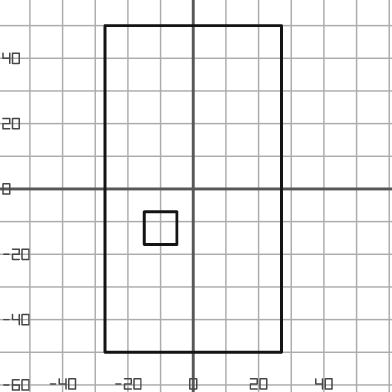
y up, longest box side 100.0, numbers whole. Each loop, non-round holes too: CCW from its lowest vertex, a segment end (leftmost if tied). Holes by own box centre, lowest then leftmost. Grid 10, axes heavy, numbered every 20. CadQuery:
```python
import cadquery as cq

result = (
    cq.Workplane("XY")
    .moveTo(-27.0, -50.0)
    .lineTo(27.0, -50.0)
    .lineTo(27.0, 50.0)
    .lineTo(-27.0, 50.0)
    .close()
    .moveTo(-15.0, -17.0)
    .lineTo(-5.0, -17.0)
    .lineTo(-5.0, -7.0)
    .lineTo(-15.0, -7.0)
    .close()
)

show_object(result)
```